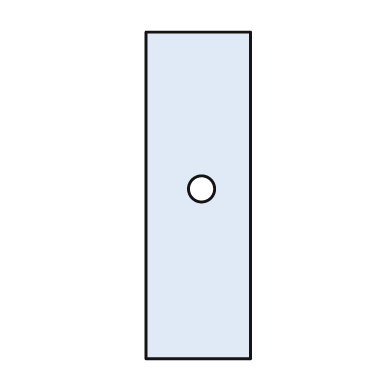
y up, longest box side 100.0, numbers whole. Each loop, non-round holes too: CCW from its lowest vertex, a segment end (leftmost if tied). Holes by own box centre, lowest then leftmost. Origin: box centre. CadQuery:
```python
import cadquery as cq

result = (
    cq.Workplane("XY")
    .moveTo(-16.0, -50.0)
    .lineTo(16.0, -50.0)
    .lineTo(16.0, 50.0)
    .lineTo(-16.0, 50.0)
    .close()
    .moveTo(1.0, 2.0)
    .circle(4.0)
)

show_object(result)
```